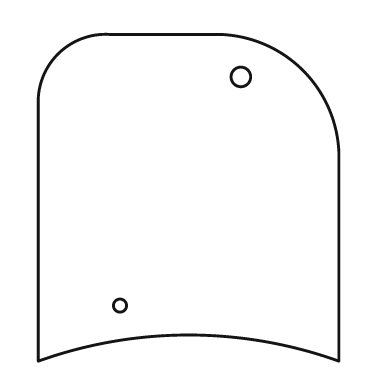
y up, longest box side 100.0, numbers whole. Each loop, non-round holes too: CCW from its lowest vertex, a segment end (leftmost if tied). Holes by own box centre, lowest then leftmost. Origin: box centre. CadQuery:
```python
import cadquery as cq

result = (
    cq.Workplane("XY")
    .moveTo(-46.0, -50.0)
    .threePointArc((0.0, -42.0), (46.0, -50.0))
    .lineTo(46.0, 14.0)
    .threePointArc((35.0, 39.0), (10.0, 50.0))
    .lineTo(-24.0, 50.0)
    .threePointArc((-40.0, 44.0), (-46.0, 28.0))
    .close()
    .moveTo(-21.0, -33.0)
    .circle(2.0)
    .moveTo(16.0, 37.0)
    .circle(3.0)
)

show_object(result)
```